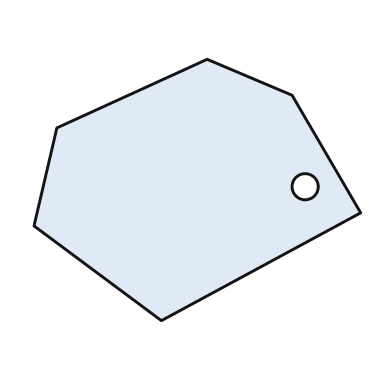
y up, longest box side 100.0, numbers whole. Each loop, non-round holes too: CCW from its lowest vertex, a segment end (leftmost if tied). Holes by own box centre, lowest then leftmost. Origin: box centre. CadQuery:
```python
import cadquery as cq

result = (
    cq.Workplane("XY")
    .moveTo(-11.0, -40.0)
    .lineTo(50.0, -7.0)
    .lineTo(29.0, 29.0)
    .lineTo(3.0, 40.0)
    .lineTo(-43.0, 19.0)
    .lineTo(-50.0, -11.0)
    .close()
    .moveTo(33.0, 1.0)
    .circle(4.0)
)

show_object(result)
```